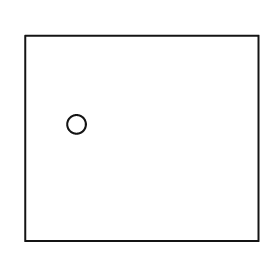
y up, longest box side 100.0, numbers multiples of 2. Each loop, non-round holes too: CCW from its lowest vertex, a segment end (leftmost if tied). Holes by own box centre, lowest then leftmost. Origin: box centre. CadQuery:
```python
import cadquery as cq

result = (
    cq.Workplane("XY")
    .moveTo(-50.0, -44.0)
    .lineTo(50.0, -44.0)
    .lineTo(50.0, 44.0)
    .lineTo(-50.0, 44.0)
    .close()
    .moveTo(-28.0, 6.0)
    .circle(4.0)
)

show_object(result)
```